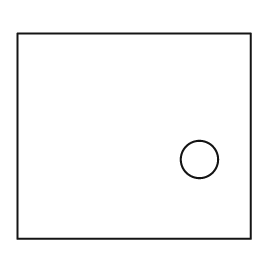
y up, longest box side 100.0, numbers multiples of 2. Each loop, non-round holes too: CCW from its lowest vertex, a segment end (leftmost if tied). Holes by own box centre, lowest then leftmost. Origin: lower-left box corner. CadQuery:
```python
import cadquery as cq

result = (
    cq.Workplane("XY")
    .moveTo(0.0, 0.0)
    .lineTo(100.0, 0.0)
    .lineTo(100.0, 88.0)
    .lineTo(0.0, 88.0)
    .close()
    .moveTo(78.0, 34.0)
    .circle(8.0)
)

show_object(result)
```